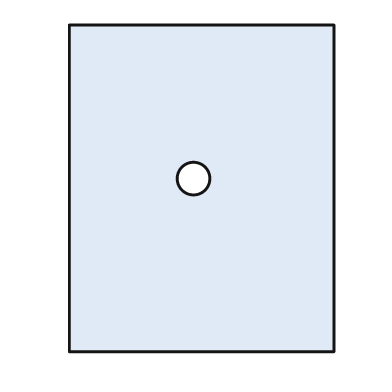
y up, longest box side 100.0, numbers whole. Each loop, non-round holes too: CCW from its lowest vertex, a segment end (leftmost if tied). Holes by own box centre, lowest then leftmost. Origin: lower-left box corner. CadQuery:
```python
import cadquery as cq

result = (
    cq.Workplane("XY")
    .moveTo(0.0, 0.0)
    .lineTo(81.0, 0.0)
    .lineTo(81.0, 100.0)
    .lineTo(0.0, 100.0)
    .close()
    .moveTo(38.0, 53.0)
    .circle(5.0)
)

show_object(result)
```